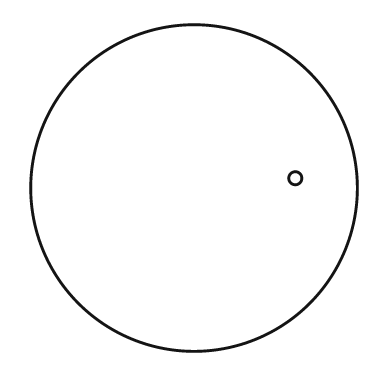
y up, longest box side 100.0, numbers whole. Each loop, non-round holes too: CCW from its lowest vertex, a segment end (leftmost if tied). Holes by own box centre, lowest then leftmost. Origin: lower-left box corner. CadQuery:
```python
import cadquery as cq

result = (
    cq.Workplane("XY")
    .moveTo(50.0, 50.0)
    .circle(50.0)
    .moveTo(81.0, 53.0)
    .circle(2.0)
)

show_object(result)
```